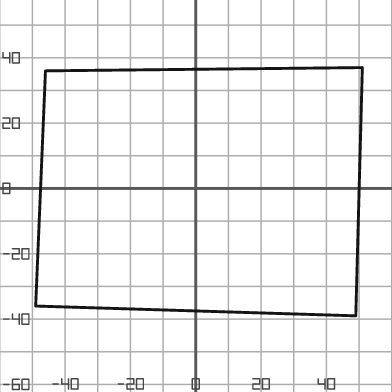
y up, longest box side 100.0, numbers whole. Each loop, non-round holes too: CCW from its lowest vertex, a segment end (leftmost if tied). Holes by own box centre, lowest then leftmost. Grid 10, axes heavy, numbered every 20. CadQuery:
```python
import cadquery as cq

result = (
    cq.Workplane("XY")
    .moveTo(49.0, -39.0)
    .lineTo(51.0, 37.0)
    .lineTo(-46.0, 36.0)
    .lineTo(-49.0, -36.0)
    .close()
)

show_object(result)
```